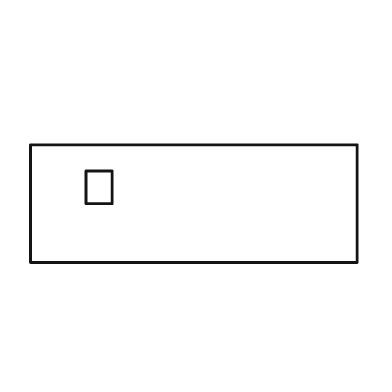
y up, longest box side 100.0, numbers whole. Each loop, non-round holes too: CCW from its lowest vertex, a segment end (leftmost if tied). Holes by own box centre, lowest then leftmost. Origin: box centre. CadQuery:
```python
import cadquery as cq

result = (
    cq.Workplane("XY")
    .moveTo(-50.0, -18.0)
    .lineTo(50.0, -18.0)
    .lineTo(50.0, 18.0)
    .lineTo(-50.0, 18.0)
    .close()
    .moveTo(-33.0, 0.0)
    .lineTo(-25.0, 0.0)
    .lineTo(-25.0, 10.0)
    .lineTo(-33.0, 10.0)
    .close()
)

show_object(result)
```